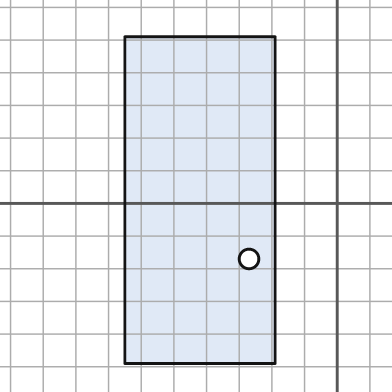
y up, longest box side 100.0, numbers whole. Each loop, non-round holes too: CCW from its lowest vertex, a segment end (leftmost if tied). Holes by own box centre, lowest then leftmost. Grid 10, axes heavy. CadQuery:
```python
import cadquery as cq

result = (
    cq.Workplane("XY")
    .moveTo(-65.0, -49.0)
    .lineTo(-19.0, -49.0)
    .lineTo(-19.0, 51.0)
    .lineTo(-65.0, 51.0)
    .close()
    .moveTo(-27.0, -17.0)
    .circle(3.0)
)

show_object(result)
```